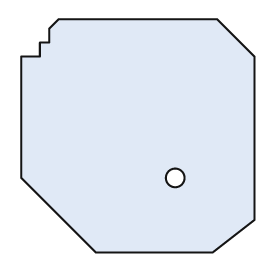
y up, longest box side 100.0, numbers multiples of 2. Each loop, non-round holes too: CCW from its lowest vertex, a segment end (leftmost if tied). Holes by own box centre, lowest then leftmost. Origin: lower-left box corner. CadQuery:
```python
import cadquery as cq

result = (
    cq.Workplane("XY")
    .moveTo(32.0, 0.0)
    .lineTo(82.0, 0.0)
    .lineTo(100.0, 14.0)
    .lineTo(100.0, 84.0)
    .lineTo(84.0, 100.0)
    .lineTo(16.0, 100.0)
    .lineTo(12.0, 96.0)
    .lineTo(12.0, 90.0)
    .lineTo(8.0, 90.0)
    .lineTo(8.0, 84.0)
    .lineTo(0.0, 84.0)
    .lineTo(0.0, 32.0)
    .close()
    .moveTo(66.0, 32.0)
    .circle(4.0)
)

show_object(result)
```